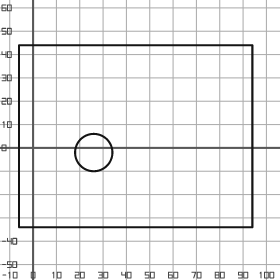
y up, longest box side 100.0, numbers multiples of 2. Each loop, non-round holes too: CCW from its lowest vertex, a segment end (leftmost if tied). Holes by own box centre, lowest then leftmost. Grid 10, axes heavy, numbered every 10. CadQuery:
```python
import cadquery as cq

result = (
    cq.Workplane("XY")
    .moveTo(-6.0, -34.0)
    .lineTo(94.0, -34.0)
    .lineTo(94.0, 44.0)
    .lineTo(-6.0, 44.0)
    .close()
    .moveTo(26.0, -2.0)
    .circle(8.0)
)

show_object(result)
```